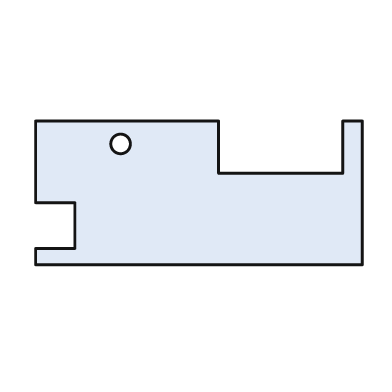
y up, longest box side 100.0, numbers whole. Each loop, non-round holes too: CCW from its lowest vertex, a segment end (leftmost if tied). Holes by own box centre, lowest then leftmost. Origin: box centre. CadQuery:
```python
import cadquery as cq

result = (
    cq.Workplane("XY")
    .moveTo(-50.0, -22.0)
    .lineTo(50.0, -22.0)
    .lineTo(50.0, 22.0)
    .lineTo(44.0, 22.0)
    .lineTo(44.0, 6.0)
    .lineTo(6.0, 6.0)
    .lineTo(6.0, 22.0)
    .lineTo(-50.0, 22.0)
    .lineTo(-50.0, -3.0)
    .lineTo(-38.0, -3.0)
    .lineTo(-38.0, -17.0)
    .lineTo(-50.0, -17.0)
    .close()
    .moveTo(-24.0, 15.0)
    .circle(3.0)
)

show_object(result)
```